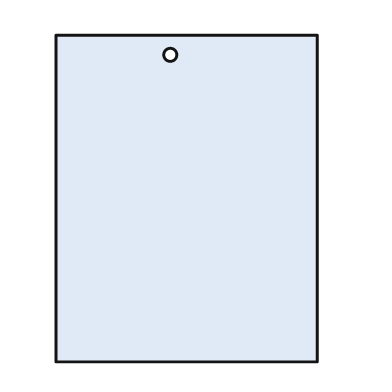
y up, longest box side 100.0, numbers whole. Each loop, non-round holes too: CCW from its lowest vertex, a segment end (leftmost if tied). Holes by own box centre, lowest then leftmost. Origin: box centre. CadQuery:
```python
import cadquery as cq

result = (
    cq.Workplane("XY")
    .moveTo(-40.0, -50.0)
    .lineTo(40.0, -50.0)
    .lineTo(40.0, 50.0)
    .lineTo(-40.0, 50.0)
    .close()
    .moveTo(-5.0, 44.0)
    .circle(2.0)
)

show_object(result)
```